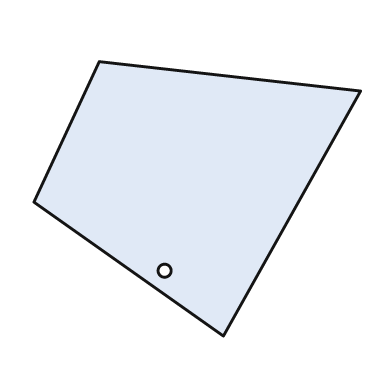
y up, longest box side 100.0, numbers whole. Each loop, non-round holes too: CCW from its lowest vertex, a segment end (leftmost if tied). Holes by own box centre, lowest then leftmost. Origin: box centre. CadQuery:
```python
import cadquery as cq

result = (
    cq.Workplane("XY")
    .moveTo(8.0, -42.0)
    .lineTo(50.0, 33.0)
    .lineTo(-30.0, 42.0)
    .lineTo(-50.0, -1.0)
    .close()
    .moveTo(-10.0, -22.0)
    .circle(2.0)
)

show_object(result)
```